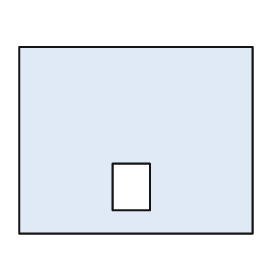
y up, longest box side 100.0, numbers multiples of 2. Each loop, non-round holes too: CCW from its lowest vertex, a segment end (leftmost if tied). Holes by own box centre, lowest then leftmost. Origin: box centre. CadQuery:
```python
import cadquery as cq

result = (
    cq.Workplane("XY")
    .moveTo(-50.0, -40.0)
    .lineTo(50.0, -40.0)
    .lineTo(50.0, 40.0)
    .lineTo(-50.0, 40.0)
    .close()
    .moveTo(-10.0, -30.0)
    .lineTo(6.0, -30.0)
    .lineTo(6.0, -10.0)
    .lineTo(-10.0, -10.0)
    .close()
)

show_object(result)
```